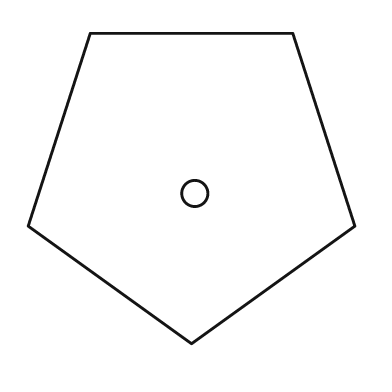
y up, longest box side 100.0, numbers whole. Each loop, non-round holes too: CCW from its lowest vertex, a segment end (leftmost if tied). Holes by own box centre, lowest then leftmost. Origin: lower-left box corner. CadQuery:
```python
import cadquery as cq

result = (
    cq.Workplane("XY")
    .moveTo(50.0, 0.0)
    .lineTo(100.0, 36.0)
    .lineTo(81.0, 95.0)
    .lineTo(19.0, 95.0)
    .lineTo(0.0, 36.0)
    .close()
    .moveTo(51.0, 46.0)
    .circle(4.0)
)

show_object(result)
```